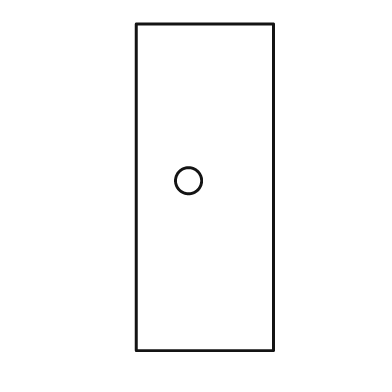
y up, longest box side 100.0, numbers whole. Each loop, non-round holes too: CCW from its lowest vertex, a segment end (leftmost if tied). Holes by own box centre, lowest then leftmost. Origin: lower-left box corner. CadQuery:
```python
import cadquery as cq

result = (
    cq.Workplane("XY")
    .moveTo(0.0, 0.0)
    .lineTo(42.0, 0.0)
    .lineTo(42.0, 100.0)
    .lineTo(0.0, 100.0)
    .close()
    .moveTo(16.0, 52.0)
    .circle(4.0)
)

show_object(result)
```